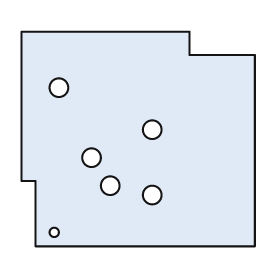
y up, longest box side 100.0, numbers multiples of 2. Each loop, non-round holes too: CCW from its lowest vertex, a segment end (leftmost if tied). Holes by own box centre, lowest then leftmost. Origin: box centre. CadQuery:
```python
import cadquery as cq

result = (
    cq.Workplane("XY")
    .moveTo(-44.0, -46.0)
    .lineTo(50.0, -46.0)
    .lineTo(50.0, 36.0)
    .lineTo(22.0, 36.0)
    .lineTo(22.0, 46.0)
    .lineTo(-50.0, 46.0)
    .lineTo(-50.0, -18.0)
    .lineTo(-44.0, -18.0)
    .close()
    .moveTo(-36.0, -40.0)
    .circle(2.0)
    .moveTo(6.0, -24.0)
    .circle(4.0)
    .moveTo(-12.0, -20.0)
    .circle(4.0)
    .moveTo(-20.0, -8.0)
    .circle(4.0)
    .moveTo(6.0, 4.0)
    .circle(4.0)
    .moveTo(-34.0, 22.0)
    .circle(4.0)
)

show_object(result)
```